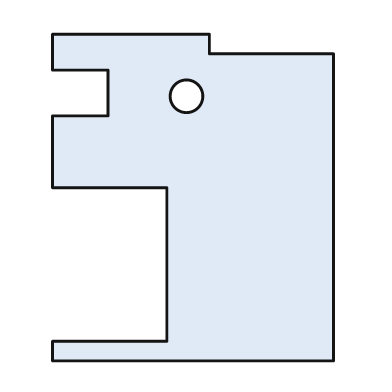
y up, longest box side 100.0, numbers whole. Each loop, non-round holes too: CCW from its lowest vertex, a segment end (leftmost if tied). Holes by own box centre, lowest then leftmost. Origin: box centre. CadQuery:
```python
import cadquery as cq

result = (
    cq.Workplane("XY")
    .moveTo(-43.0, -50.0)
    .lineTo(43.0, -50.0)
    .lineTo(43.0, 44.0)
    .lineTo(5.0, 44.0)
    .lineTo(5.0, 50.0)
    .lineTo(-43.0, 50.0)
    .lineTo(-43.0, 39.0)
    .lineTo(-26.0, 39.0)
    .lineTo(-26.0, 25.0)
    .lineTo(-43.0, 25.0)
    .lineTo(-43.0, 3.0)
    .lineTo(-8.0, 3.0)
    .lineTo(-8.0, -44.0)
    .lineTo(-43.0, -44.0)
    .close()
    .moveTo(-2.0, 31.0)
    .circle(5.0)
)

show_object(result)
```